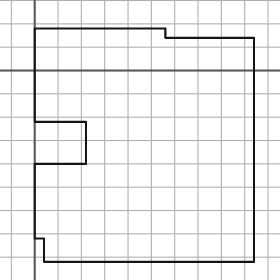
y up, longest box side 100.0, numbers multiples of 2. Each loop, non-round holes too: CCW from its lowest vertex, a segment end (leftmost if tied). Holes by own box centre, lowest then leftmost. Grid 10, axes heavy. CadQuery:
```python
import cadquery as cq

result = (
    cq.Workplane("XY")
    .moveTo(4.0, -82.0)
    .lineTo(94.0, -82.0)
    .lineTo(94.0, 14.0)
    .lineTo(56.0, 14.0)
    .lineTo(56.0, 18.0)
    .lineTo(0.0, 18.0)
    .lineTo(0.0, -22.0)
    .lineTo(22.0, -22.0)
    .lineTo(22.0, -40.0)
    .lineTo(0.0, -40.0)
    .lineTo(0.0, -72.0)
    .lineTo(4.0, -72.0)
    .close()
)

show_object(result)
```